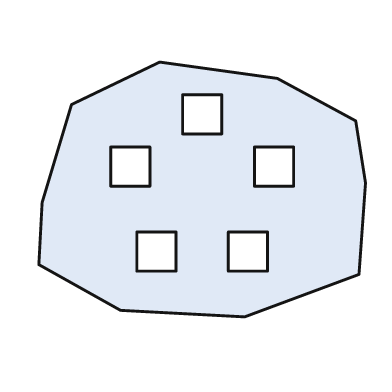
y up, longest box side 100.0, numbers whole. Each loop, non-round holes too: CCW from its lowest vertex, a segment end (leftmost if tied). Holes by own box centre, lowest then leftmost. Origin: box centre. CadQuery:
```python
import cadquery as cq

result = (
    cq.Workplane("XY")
    .moveTo(13.0, -39.0)
    .lineTo(48.0, -26.0)
    .lineTo(50.0, 2.0)
    .lineTo(47.0, 21.0)
    .lineTo(23.0, 34.0)
    .lineTo(-13.0, 39.0)
    .lineTo(-40.0, 26.0)
    .lineTo(-49.0, -4.0)
    .lineTo(-50.0, -23.0)
    .lineTo(-25.0, -37.0)
    .close()
    .moveTo(-20.0, -25.0)
    .lineTo(-8.0, -25.0)
    .lineTo(-8.0, -13.0)
    .lineTo(-20.0, -13.0)
    .close()
    .moveTo(8.0, -25.0)
    .lineTo(20.0, -25.0)
    .lineTo(20.0, -13.0)
    .lineTo(8.0, -13.0)
    .close()
    .moveTo(-28.0, 1.0)
    .lineTo(-16.0, 1.0)
    .lineTo(-16.0, 13.0)
    .lineTo(-28.0, 13.0)
    .close()
    .moveTo(16.0, 1.0)
    .lineTo(28.0, 1.0)
    .lineTo(28.0, 13.0)
    .lineTo(16.0, 13.0)
    .close()
    .moveTo(-6.0, 17.0)
    .lineTo(6.0, 17.0)
    .lineTo(6.0, 29.0)
    .lineTo(-6.0, 29.0)
    .close()
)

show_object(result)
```